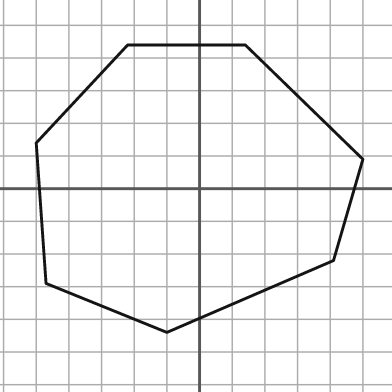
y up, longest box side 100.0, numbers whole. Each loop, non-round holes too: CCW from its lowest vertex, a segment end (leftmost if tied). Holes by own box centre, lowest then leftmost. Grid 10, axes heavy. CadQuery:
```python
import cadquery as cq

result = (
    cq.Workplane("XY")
    .moveTo(-10.0, -44.0)
    .lineTo(41.0, -22.0)
    .lineTo(50.0, 9.0)
    .lineTo(14.0, 44.0)
    .lineTo(-22.0, 44.0)
    .lineTo(-50.0, 14.0)
    .lineTo(-47.0, -29.0)
    .close()
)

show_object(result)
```